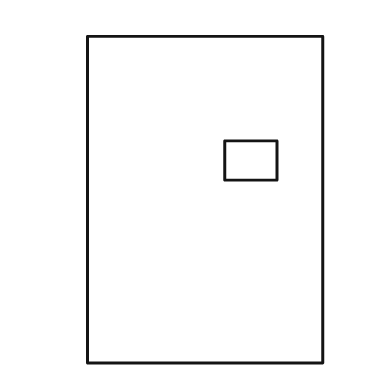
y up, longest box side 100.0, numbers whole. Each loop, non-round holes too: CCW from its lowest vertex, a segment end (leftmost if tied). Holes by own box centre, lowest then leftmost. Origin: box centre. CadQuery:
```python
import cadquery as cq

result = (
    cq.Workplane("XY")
    .moveTo(-36.0, -50.0)
    .lineTo(36.0, -50.0)
    .lineTo(36.0, 50.0)
    .lineTo(-36.0, 50.0)
    .close()
    .moveTo(6.0, 6.0)
    .lineTo(22.0, 6.0)
    .lineTo(22.0, 18.0)
    .lineTo(6.0, 18.0)
    .close()
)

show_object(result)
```